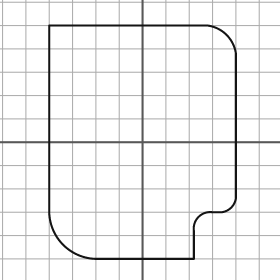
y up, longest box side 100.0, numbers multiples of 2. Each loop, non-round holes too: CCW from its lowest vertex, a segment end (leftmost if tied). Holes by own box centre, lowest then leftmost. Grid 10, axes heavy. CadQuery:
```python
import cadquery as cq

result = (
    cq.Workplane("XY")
    .moveTo(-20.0, -50.0)
    .lineTo(22.0, -50.0)
    .lineTo(22.0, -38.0)
    .threePointArc((24.0, -32.0), (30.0, -30.0))
    .lineTo(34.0, -30.0)
    .threePointArc((38.0, -28.0), (40.0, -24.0))
    .lineTo(40.0, 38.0)
    .threePointArc((36.0, 46.0), (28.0, 50.0))
    .lineTo(-40.0, 50.0)
    .lineTo(-40.0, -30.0)
    .threePointArc((-34.0, -44.0), (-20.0, -50.0))
    .close()
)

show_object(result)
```